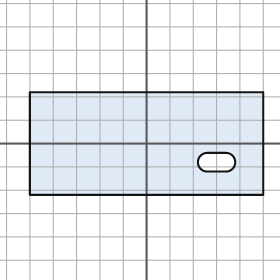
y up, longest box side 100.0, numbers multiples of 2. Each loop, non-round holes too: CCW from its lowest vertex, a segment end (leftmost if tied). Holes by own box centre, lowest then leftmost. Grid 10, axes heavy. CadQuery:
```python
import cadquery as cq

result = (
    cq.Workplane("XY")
    .moveTo(-50.0, -22.0)
    .lineTo(50.0, -22.0)
    .lineTo(50.0, 22.0)
    .lineTo(-50.0, 22.0)
    .close()
    .moveTo(26.0, -12.0)
    .lineTo(34.0, -12.0)
    .threePointArc((38.0, -8.0), (34.0, -4.0))
    .lineTo(26.0, -4.0)
    .threePointArc((22.0, -8.0), (26.0, -12.0))
    .close()
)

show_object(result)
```